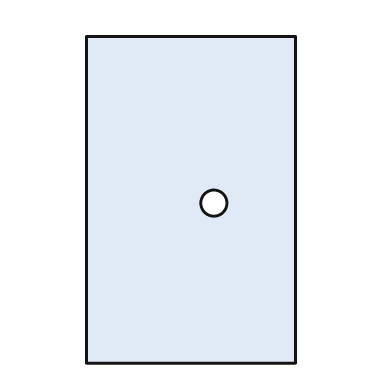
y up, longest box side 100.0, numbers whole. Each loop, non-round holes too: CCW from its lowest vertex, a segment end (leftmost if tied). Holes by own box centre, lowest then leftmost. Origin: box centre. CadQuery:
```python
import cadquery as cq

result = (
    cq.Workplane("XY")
    .moveTo(-32.0, -50.0)
    .lineTo(32.0, -50.0)
    .lineTo(32.0, 50.0)
    .lineTo(-32.0, 50.0)
    .close()
    .moveTo(7.0, -1.0)
    .circle(4.0)
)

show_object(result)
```